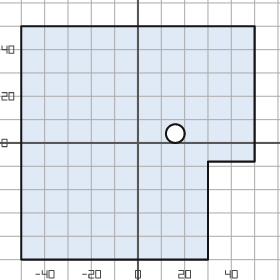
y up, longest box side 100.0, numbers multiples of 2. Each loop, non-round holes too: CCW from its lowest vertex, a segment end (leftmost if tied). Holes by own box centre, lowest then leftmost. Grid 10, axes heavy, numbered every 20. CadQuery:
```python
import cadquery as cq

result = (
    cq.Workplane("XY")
    .moveTo(-50.0, -50.0)
    .lineTo(30.0, -50.0)
    .lineTo(30.0, -8.0)
    .lineTo(50.0, -8.0)
    .lineTo(50.0, 50.0)
    .lineTo(-50.0, 50.0)
    .close()
    .moveTo(16.0, 4.0)
    .circle(4.0)
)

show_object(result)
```